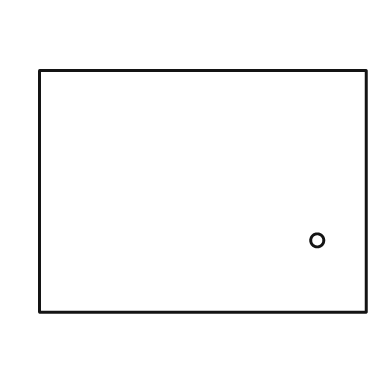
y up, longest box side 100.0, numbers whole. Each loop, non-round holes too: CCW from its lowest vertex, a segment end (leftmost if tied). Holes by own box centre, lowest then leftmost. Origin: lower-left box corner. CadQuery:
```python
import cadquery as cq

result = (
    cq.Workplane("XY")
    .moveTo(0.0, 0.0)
    .lineTo(100.0, 0.0)
    .lineTo(100.0, 74.0)
    .lineTo(0.0, 74.0)
    .close()
    .moveTo(85.0, 22.0)
    .circle(2.0)
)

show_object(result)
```